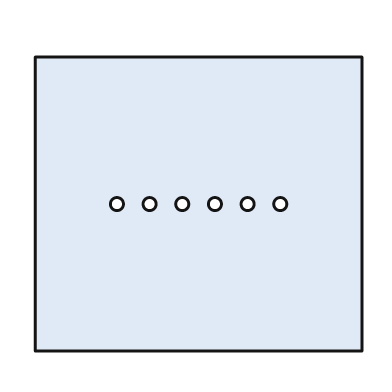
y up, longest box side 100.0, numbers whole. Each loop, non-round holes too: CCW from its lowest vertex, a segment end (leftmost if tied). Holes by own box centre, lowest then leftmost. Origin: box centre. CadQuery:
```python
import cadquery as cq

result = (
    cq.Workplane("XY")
    .moveTo(-50.0, -45.0)
    .lineTo(50.0, -45.0)
    .lineTo(50.0, 45.0)
    .lineTo(-50.0, 45.0)
    .close()
    .moveTo(-25.0, 0.0)
    .circle(2.0)
    .moveTo(-15.0, 0.0)
    .circle(2.0)
    .moveTo(-5.0, 0.0)
    .circle(2.0)
    .moveTo(5.0, 0.0)
    .circle(2.0)
    .moveTo(15.0, 0.0)
    .circle(2.0)
    .moveTo(25.0, 0.0)
    .circle(2.0)
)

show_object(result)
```